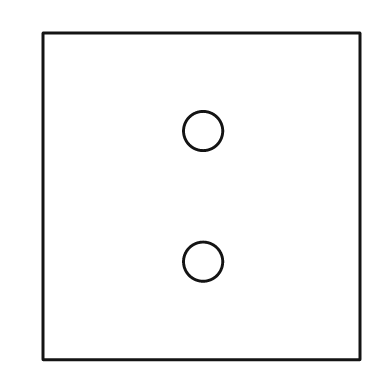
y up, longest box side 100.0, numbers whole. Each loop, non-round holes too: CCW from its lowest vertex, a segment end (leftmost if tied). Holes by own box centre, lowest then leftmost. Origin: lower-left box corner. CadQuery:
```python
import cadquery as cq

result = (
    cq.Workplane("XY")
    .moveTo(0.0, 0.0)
    .lineTo(97.0, 0.0)
    .lineTo(97.0, 100.0)
    .lineTo(0.0, 100.0)
    .close()
    .moveTo(49.0, 30.0)
    .circle(6.0)
    .moveTo(49.0, 70.0)
    .circle(6.0)
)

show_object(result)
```